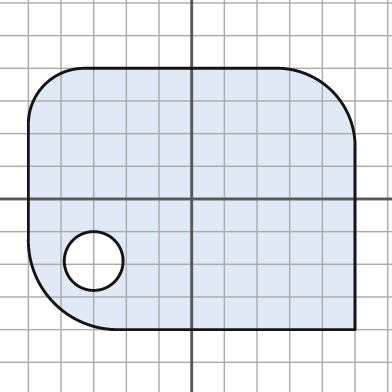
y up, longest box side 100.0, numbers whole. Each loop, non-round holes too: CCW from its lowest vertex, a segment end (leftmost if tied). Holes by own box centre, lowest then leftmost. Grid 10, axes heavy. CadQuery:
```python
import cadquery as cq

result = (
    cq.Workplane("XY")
    .moveTo(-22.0, -40.0)
    .lineTo(50.0, -40.0)
    .lineTo(50.0, 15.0)
    .threePointArc((43.0, 33.0), (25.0, 40.0))
    .lineTo(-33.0, 40.0)
    .threePointArc((-45.0, 35.0), (-50.0, 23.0))
    .lineTo(-50.0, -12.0)
    .threePointArc((-42.0, -32.0), (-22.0, -40.0))
    .close()
    .moveTo(-30.0, -19.0)
    .circle(9.0)
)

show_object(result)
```